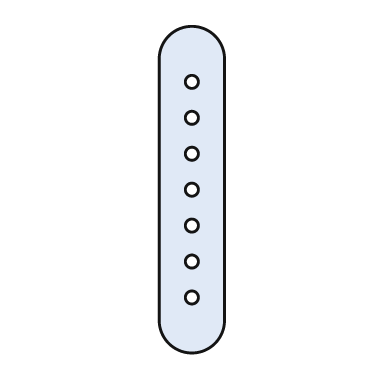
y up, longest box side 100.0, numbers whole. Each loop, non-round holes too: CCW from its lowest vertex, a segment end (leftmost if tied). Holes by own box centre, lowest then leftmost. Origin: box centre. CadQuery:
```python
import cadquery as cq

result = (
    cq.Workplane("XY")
    .moveTo(-10.0, -40.0)
    .threePointArc((0.0, -50.0), (10.0, -40.0))
    .lineTo(10.0, 40.0)
    .threePointArc((0.0, 50.0), (-10.0, 40.0))
    .close()
    .moveTo(0.0, -33.0)
    .circle(2.0)
    .moveTo(0.0, -22.0)
    .circle(2.0)
    .moveTo(0.0, -11.0)
    .circle(2.0)
    .moveTo(0.0, 0.0)
    .circle(2.0)
    .moveTo(0.0, 11.0)
    .circle(2.0)
    .moveTo(0.0, 22.0)
    .circle(2.0)
    .moveTo(0.0, 33.0)
    .circle(2.0)
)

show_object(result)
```